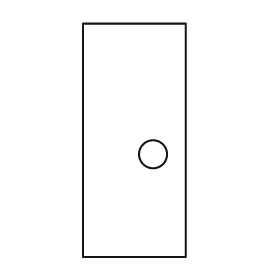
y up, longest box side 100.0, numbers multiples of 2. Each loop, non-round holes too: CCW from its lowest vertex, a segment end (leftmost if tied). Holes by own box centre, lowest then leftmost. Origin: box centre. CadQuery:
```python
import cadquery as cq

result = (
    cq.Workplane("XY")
    .moveTo(-22.0, -50.0)
    .lineTo(22.0, -50.0)
    .lineTo(22.0, 50.0)
    .lineTo(-22.0, 50.0)
    .close()
    .moveTo(8.0, -6.0)
    .circle(6.0)
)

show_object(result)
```